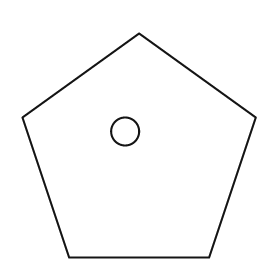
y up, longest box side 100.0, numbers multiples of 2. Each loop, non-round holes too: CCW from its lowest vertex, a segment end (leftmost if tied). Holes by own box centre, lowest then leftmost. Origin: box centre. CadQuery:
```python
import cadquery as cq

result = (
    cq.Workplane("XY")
    .moveTo(-30.0, -48.0)
    .lineTo(30.0, -48.0)
    .lineTo(50.0, 12.0)
    .lineTo(0.0, 48.0)
    .lineTo(-50.0, 12.0)
    .close()
    .moveTo(-6.0, 6.0)
    .circle(6.0)
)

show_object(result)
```